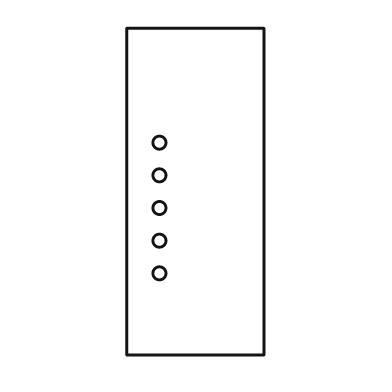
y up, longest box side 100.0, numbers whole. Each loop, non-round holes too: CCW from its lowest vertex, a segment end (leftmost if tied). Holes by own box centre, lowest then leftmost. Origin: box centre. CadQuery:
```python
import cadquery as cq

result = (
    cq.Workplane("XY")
    .moveTo(-21.0, -50.0)
    .lineTo(21.0, -50.0)
    .lineTo(21.0, 50.0)
    .lineTo(-21.0, 50.0)
    .close()
    .moveTo(-11.0, -25.0)
    .circle(2.0)
    .moveTo(-11.0, -15.0)
    .circle(2.0)
    .moveTo(-11.0, -5.0)
    .circle(2.0)
    .moveTo(-11.0, 5.0)
    .circle(2.0)
    .moveTo(-11.0, 15.0)
    .circle(2.0)
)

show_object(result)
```